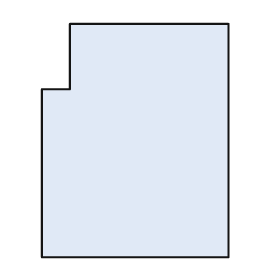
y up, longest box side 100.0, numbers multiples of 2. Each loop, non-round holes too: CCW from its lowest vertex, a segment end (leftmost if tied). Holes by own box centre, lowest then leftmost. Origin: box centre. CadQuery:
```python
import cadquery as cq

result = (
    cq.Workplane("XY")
    .moveTo(-40.0, -50.0)
    .lineTo(40.0, -50.0)
    .lineTo(40.0, 50.0)
    .lineTo(-28.0, 50.0)
    .lineTo(-28.0, 22.0)
    .lineTo(-40.0, 22.0)
    .close()
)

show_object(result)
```